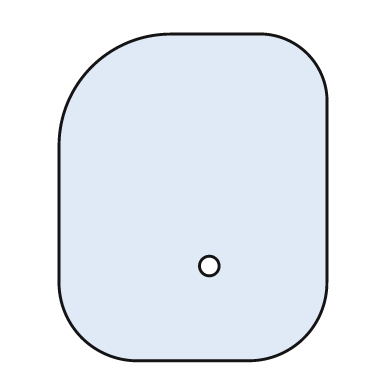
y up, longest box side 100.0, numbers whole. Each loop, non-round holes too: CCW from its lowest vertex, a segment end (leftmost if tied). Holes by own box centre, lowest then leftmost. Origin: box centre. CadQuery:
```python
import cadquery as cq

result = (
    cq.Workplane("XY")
    .moveTo(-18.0, -50.0)
    .lineTo(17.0, -50.0)
    .threePointArc((34.0, -43.0), (41.0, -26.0))
    .lineTo(41.0, 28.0)
    .threePointArc((35.0, 44.0), (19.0, 50.0))
    .lineTo(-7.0, 50.0)
    .threePointArc((-31.0, 40.0), (-41.0, 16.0))
    .lineTo(-41.0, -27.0)
    .threePointArc((-34.0, -43.0), (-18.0, -50.0))
    .close()
    .moveTo(5.0, -21.0)
    .circle(3.0)
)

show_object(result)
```